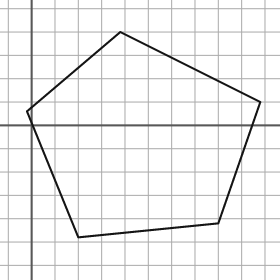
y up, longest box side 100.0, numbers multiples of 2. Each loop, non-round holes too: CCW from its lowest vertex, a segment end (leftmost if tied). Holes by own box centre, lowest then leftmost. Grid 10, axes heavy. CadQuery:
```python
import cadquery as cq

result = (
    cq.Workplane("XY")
    .moveTo(20.0, -48.0)
    .lineTo(80.0, -42.0)
    .lineTo(98.0, 10.0)
    .lineTo(38.0, 40.0)
    .lineTo(-2.0, 6.0)
    .close()
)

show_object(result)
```